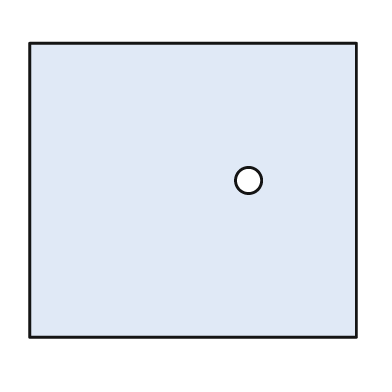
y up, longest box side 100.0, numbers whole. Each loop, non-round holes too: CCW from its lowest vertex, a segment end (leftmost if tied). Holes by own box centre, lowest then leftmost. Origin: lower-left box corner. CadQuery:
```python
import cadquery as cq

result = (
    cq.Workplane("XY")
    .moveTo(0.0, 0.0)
    .lineTo(100.0, 0.0)
    .lineTo(100.0, 90.0)
    .lineTo(0.0, 90.0)
    .close()
    .moveTo(67.0, 48.0)
    .circle(4.0)
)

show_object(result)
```